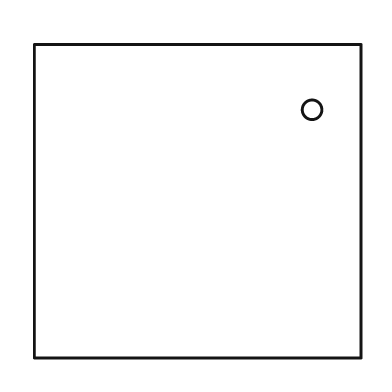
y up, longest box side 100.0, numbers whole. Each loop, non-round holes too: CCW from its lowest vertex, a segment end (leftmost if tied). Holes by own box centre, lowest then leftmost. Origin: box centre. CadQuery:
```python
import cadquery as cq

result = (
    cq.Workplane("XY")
    .moveTo(-50.0, -48.0)
    .lineTo(50.0, -48.0)
    .lineTo(50.0, 48.0)
    .lineTo(-50.0, 48.0)
    .close()
    .moveTo(35.0, 28.0)
    .circle(3.0)
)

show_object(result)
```